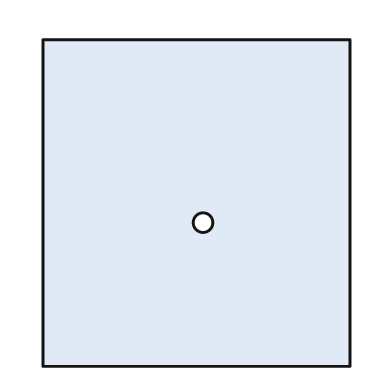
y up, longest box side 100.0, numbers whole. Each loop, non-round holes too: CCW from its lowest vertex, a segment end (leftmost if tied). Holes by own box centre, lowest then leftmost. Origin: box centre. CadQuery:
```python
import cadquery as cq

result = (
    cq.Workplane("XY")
    .moveTo(-47.0, -50.0)
    .lineTo(47.0, -50.0)
    .lineTo(47.0, 50.0)
    .lineTo(-47.0, 50.0)
    .close()
    .moveTo(2.0, -6.0)
    .circle(3.0)
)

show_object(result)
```